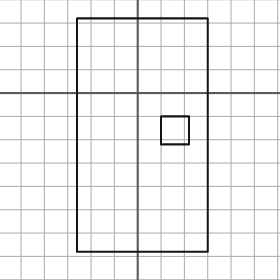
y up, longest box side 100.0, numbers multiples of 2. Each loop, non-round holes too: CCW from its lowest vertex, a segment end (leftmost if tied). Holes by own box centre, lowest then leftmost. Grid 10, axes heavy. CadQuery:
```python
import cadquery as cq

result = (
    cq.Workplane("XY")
    .moveTo(-26.0, -68.0)
    .lineTo(30.0, -68.0)
    .lineTo(30.0, 32.0)
    .lineTo(-26.0, 32.0)
    .close()
    .moveTo(10.0, -22.0)
    .lineTo(22.0, -22.0)
    .lineTo(22.0, -10.0)
    .lineTo(10.0, -10.0)
    .close()
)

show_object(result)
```